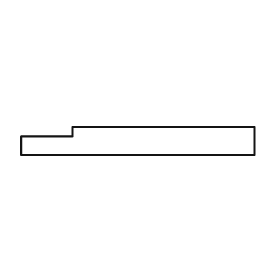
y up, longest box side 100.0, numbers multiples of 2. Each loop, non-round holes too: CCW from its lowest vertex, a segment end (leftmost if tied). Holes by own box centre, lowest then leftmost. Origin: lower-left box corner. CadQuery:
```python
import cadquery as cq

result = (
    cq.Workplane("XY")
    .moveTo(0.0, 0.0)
    .lineTo(100.0, 0.0)
    .lineTo(100.0, 12.0)
    .lineTo(22.0, 12.0)
    .lineTo(22.0, 8.0)
    .lineTo(0.0, 8.0)
    .close()
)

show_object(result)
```